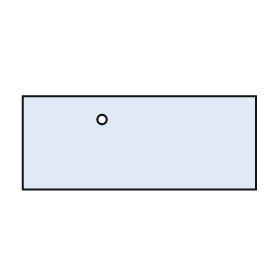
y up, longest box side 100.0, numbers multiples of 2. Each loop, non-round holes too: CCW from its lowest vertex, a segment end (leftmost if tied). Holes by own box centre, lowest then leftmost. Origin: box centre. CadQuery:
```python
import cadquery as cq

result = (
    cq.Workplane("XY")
    .moveTo(-50.0, -20.0)
    .lineTo(50.0, -20.0)
    .lineTo(50.0, 20.0)
    .lineTo(-50.0, 20.0)
    .close()
    .moveTo(-16.0, 10.0)
    .circle(2.0)
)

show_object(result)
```